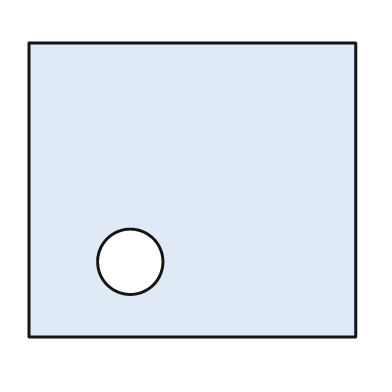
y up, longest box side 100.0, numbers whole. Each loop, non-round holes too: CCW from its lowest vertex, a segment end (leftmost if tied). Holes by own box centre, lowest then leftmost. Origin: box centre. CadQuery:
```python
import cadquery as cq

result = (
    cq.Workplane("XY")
    .moveTo(-50.0, -45.0)
    .lineTo(50.0, -45.0)
    .lineTo(50.0, 45.0)
    .lineTo(-50.0, 45.0)
    .close()
    .moveTo(-19.0, -22.0)
    .circle(10.0)
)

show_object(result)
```